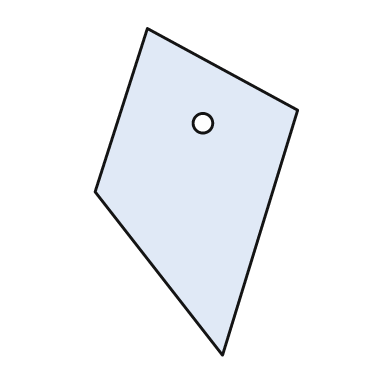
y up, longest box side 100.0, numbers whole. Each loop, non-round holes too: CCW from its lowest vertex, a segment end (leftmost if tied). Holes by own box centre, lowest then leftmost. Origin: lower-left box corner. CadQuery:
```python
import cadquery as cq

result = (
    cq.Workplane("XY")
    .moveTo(39.0, 0.0)
    .lineTo(62.0, 75.0)
    .lineTo(16.0, 100.0)
    .lineTo(0.0, 50.0)
    .close()
    .moveTo(33.0, 71.0)
    .circle(3.0)
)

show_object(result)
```